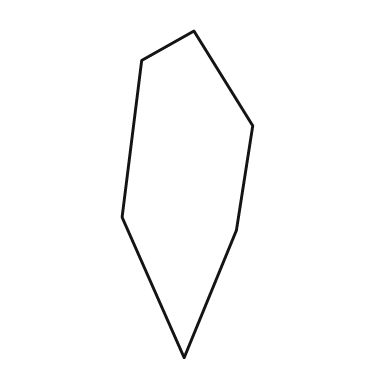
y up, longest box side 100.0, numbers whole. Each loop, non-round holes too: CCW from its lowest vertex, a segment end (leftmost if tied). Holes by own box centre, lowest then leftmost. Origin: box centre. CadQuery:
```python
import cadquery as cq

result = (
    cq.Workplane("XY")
    .moveTo(-1.0, -50.0)
    .lineTo(15.0, -11.0)
    .lineTo(20.0, 21.0)
    .lineTo(2.0, 50.0)
    .lineTo(-14.0, 41.0)
    .lineTo(-20.0, -7.0)
    .close()
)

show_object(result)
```